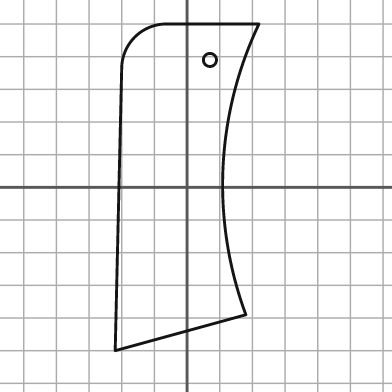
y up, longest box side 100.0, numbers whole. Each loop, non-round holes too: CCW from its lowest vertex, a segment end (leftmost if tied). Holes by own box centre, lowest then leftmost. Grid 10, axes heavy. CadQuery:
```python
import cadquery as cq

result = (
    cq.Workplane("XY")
    .moveTo(-22.0, -50.0)
    .lineTo(18.0, -39.0)
    .threePointArc((11.0, 6.0), (22.0, 50.0))
    .lineTo(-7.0, 50.0)
    .threePointArc((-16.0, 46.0), (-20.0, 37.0))
    .close()
    .moveTo(7.0, 39.0)
    .circle(2.0)
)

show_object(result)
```